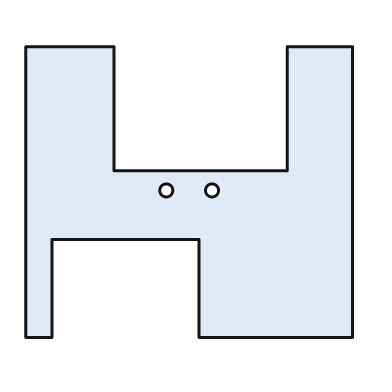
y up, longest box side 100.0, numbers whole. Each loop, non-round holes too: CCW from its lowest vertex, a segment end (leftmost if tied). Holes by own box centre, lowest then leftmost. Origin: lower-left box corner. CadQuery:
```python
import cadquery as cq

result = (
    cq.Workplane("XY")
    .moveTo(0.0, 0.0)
    .lineTo(8.0, 0.0)
    .lineTo(8.0, 30.0)
    .lineTo(53.0, 30.0)
    .lineTo(53.0, 0.0)
    .lineTo(100.0, 0.0)
    .lineTo(100.0, 89.0)
    .lineTo(80.0, 89.0)
    .lineTo(80.0, 51.0)
    .lineTo(27.0, 51.0)
    .lineTo(27.0, 89.0)
    .lineTo(0.0, 89.0)
    .close()
    .moveTo(43.0, 45.0)
    .circle(2.0)
    .moveTo(57.0, 45.0)
    .circle(2.0)
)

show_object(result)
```